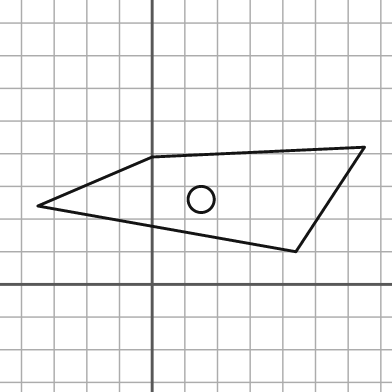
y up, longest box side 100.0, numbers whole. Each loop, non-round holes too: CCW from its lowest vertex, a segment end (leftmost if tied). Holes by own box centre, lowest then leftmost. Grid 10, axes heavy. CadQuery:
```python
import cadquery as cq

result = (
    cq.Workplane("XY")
    .moveTo(44.0, 10.0)
    .lineTo(65.0, 42.0)
    .lineTo(0.0, 39.0)
    .lineTo(-35.0, 24.0)
    .close()
    .moveTo(15.0, 26.0)
    .circle(4.0)
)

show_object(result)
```